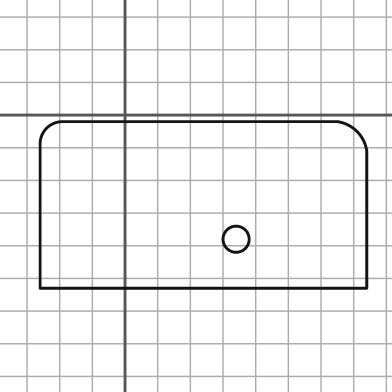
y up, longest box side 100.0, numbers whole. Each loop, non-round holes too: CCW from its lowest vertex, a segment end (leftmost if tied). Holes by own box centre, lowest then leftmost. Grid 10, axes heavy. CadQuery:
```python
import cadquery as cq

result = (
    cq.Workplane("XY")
    .moveTo(-26.0, -53.0)
    .lineTo(74.0, -53.0)
    .lineTo(74.0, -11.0)
    .threePointArc((71.0, -5.0), (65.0, -2.0))
    .lineTo(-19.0, -2.0)
    .threePointArc((-24.0, -4.0), (-26.0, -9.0))
    .close()
    .moveTo(34.0, -38.0)
    .circle(4.0)
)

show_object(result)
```